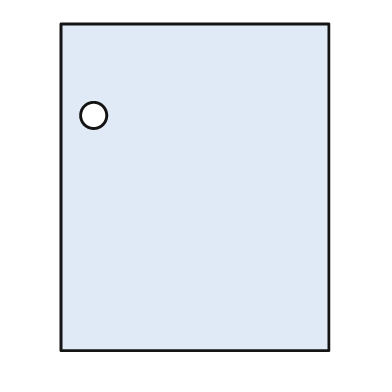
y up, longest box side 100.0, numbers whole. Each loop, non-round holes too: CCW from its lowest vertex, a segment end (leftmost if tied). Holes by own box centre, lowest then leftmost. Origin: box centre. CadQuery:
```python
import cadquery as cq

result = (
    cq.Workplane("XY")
    .moveTo(-41.0, -50.0)
    .lineTo(41.0, -50.0)
    .lineTo(41.0, 50.0)
    .lineTo(-41.0, 50.0)
    .close()
    .moveTo(-31.0, 22.0)
    .circle(4.0)
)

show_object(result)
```